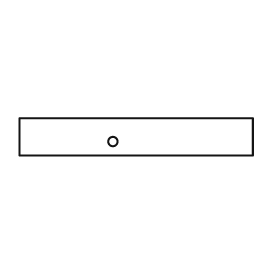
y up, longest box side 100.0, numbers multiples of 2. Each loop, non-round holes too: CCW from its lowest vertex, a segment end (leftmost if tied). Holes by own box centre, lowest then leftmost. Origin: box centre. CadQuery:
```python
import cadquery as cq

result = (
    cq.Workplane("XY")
    .moveTo(-50.0, -8.0)
    .lineTo(50.0, -8.0)
    .lineTo(50.0, 8.0)
    .lineTo(-50.0, 8.0)
    .close()
    .moveTo(-10.0, -2.0)
    .circle(2.0)
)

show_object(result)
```